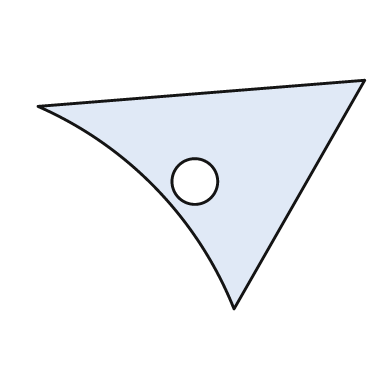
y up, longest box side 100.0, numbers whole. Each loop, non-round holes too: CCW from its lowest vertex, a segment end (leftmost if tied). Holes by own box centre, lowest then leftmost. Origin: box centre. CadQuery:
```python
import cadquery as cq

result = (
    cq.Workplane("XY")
    .moveTo(10.0, -35.0)
    .lineTo(50.0, 35.0)
    .lineTo(-50.0, 27.0)
    .threePointArc((-14.0, 2.0), (10.0, -35.0))
    .close()
    .moveTo(-2.0, 4.0)
    .circle(7.0)
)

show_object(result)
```